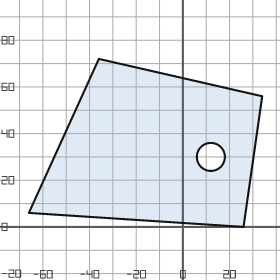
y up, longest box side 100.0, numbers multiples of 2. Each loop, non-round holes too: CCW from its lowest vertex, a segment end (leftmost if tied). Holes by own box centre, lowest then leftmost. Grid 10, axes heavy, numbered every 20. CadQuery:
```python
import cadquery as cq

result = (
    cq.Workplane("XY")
    .moveTo(26.0, 0.0)
    .lineTo(34.0, 56.0)
    .lineTo(-36.0, 72.0)
    .lineTo(-66.0, 6.0)
    .close()
    .moveTo(12.0, 30.0)
    .circle(6.0)
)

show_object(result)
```